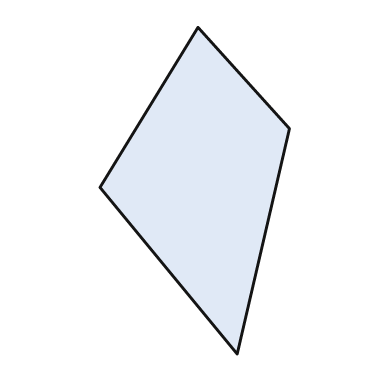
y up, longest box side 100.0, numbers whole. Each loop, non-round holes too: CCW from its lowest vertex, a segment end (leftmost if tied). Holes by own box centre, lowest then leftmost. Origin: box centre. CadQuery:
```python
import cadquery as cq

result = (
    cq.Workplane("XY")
    .moveTo(13.0, -50.0)
    .lineTo(29.0, 19.0)
    .lineTo(1.0, 50.0)
    .lineTo(-29.0, 1.0)
    .close()
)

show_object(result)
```